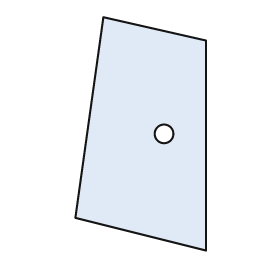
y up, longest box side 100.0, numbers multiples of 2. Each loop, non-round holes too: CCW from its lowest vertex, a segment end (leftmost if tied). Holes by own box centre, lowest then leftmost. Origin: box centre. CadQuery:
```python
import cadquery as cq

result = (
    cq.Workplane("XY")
    .moveTo(28.0, -50.0)
    .lineTo(28.0, 40.0)
    .lineTo(-16.0, 50.0)
    .lineTo(-28.0, -36.0)
    .close()
    .moveTo(10.0, 0.0)
    .circle(4.0)
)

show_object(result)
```